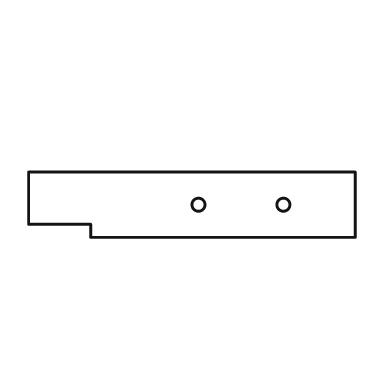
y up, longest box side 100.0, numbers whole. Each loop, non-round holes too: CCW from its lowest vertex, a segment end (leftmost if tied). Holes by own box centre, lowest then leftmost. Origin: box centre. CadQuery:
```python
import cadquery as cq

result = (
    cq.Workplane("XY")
    .moveTo(-31.0, -10.0)
    .lineTo(50.0, -10.0)
    .lineTo(50.0, 10.0)
    .lineTo(-50.0, 10.0)
    .lineTo(-50.0, -6.0)
    .lineTo(-31.0, -6.0)
    .close()
    .moveTo(2.0, 0.0)
    .circle(2.0)
    .moveTo(28.0, 0.0)
    .circle(2.0)
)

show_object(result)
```